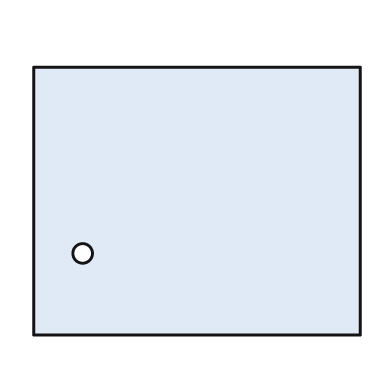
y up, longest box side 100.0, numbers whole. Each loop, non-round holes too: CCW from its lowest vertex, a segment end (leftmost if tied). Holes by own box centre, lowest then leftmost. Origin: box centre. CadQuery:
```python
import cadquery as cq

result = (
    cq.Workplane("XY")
    .moveTo(-50.0, -41.0)
    .lineTo(50.0, -41.0)
    .lineTo(50.0, 41.0)
    .lineTo(-50.0, 41.0)
    .close()
    .moveTo(-35.0, -16.0)
    .circle(3.0)
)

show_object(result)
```